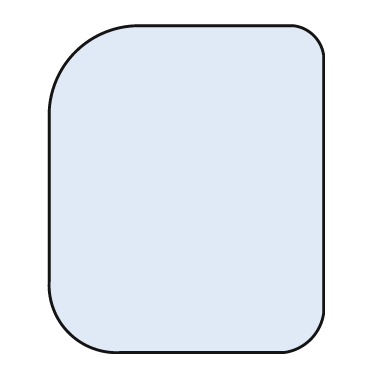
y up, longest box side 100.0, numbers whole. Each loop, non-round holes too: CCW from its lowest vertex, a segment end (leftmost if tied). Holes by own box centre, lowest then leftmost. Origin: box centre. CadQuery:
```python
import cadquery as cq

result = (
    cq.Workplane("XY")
    .moveTo(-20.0, -50.0)
    .lineTo(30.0, -50.0)
    .threePointArc((38.0, -46.0), (42.0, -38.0))
    .lineTo(42.0, 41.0)
    .threePointArc((39.0, 47.0), (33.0, 50.0))
    .lineTo(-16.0, 50.0)
    .threePointArc((-34.0, 42.0), (-42.0, 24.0))
    .lineTo(-42.0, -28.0)
    .threePointArc((-36.0, -44.0), (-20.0, -50.0))
    .close()
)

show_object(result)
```